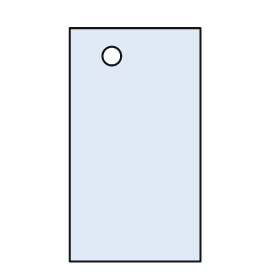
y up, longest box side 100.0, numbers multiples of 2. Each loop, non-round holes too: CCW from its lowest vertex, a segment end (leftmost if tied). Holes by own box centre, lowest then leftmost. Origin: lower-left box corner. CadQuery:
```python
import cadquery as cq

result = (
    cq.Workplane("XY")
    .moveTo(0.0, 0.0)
    .lineTo(56.0, 0.0)
    .lineTo(56.0, 100.0)
    .lineTo(0.0, 100.0)
    .close()
    .moveTo(18.0, 88.0)
    .circle(4.0)
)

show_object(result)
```